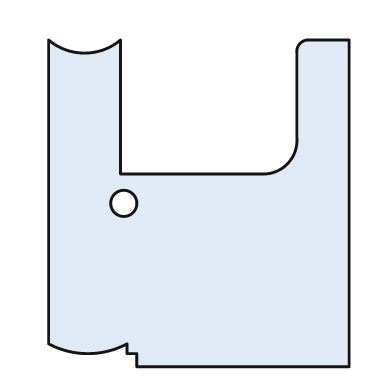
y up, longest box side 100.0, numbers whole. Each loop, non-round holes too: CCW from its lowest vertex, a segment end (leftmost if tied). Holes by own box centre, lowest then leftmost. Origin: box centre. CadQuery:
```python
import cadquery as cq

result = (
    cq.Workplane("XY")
    .moveTo(-19.0, -50.0)
    .lineTo(46.0, -50.0)
    .lineTo(46.0, 50.0)
    .lineTo(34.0, 50.0)
    .threePointArc((31.0, 49.0), (30.0, 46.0))
    .lineTo(30.0, 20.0)
    .threePointArc((27.0, 12.0), (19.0, 9.0))
    .lineTo(-24.0, 9.0)
    .lineTo(-24.0, 50.0)
    .threePointArc((-35.0, 46.0), (-46.0, 50.0))
    .lineTo(-46.0, -43.0)
    .threePointArc((-34.0, -46.0), (-22.0, -43.0))
    .lineTo(-22.0, -46.0)
    .lineTo(-19.0, -46.0)
    .close()
    .moveTo(-23.0, 0.0)
    .circle(4.0)
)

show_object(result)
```